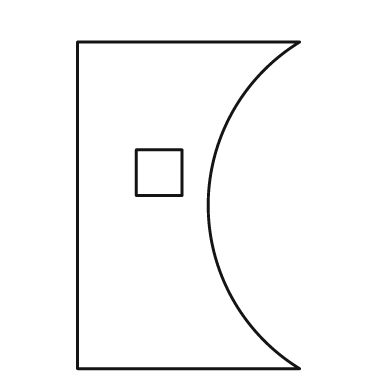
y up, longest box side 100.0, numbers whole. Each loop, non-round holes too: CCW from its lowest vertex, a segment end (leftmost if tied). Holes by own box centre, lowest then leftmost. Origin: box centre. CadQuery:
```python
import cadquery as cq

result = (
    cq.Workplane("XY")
    .moveTo(-34.0, -50.0)
    .lineTo(34.0, -50.0)
    .threePointArc((6.0, 0.0), (34.0, 50.0))
    .lineTo(-34.0, 50.0)
    .close()
    .moveTo(-16.0, 3.0)
    .lineTo(-2.0, 3.0)
    .lineTo(-2.0, 17.0)
    .lineTo(-16.0, 17.0)
    .close()
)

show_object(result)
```